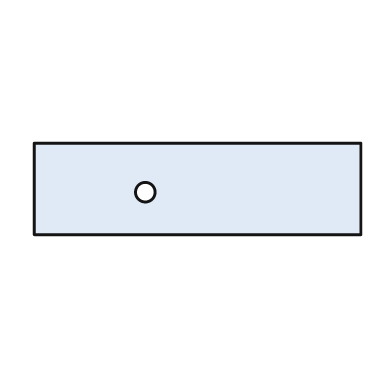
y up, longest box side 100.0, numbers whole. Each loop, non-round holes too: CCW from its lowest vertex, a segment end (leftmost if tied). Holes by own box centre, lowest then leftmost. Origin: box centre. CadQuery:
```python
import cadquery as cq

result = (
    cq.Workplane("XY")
    .moveTo(-50.0, -14.0)
    .lineTo(50.0, -14.0)
    .lineTo(50.0, 14.0)
    .lineTo(-50.0, 14.0)
    .close()
    .moveTo(-16.0, -1.0)
    .circle(3.0)
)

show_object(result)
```